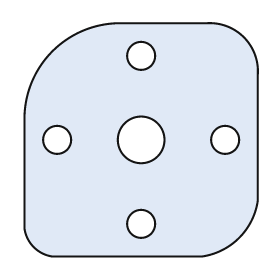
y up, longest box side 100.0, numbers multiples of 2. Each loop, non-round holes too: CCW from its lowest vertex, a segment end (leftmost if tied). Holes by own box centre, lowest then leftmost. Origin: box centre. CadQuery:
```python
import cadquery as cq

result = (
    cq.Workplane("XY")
    .moveTo(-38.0, -50.0)
    .lineTo(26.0, -50.0)
    .threePointArc((42.0, -42.0), (50.0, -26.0))
    .lineTo(50.0, 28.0)
    .threePointArc((44.0, 44.0), (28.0, 50.0))
    .lineTo(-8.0, 50.0)
    .threePointArc((-38.0, 38.0), (-50.0, 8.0))
    .lineTo(-50.0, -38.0)
    .threePointArc((-46.0, -46.0), (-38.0, -50.0))
    .close()
    .moveTo(0.0, -36.0)
    .circle(6.0)
    .moveTo(-36.0, 0.0)
    .circle(6.0)
    .moveTo(0.0, 0.0)
    .circle(10.0)
    .moveTo(36.0, 0.0)
    .circle(6.0)
    .moveTo(0.0, 36.0)
    .circle(6.0)
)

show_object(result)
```